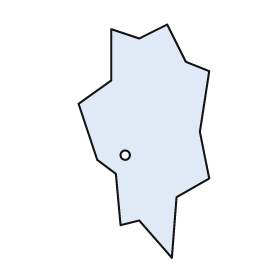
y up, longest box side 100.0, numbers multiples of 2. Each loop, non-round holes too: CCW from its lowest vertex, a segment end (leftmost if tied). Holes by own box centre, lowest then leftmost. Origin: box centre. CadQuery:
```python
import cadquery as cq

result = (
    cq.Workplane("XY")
    .moveTo(12.0, -50.0)
    .lineTo(14.0, -24.0)
    .lineTo(28.0, -16.0)
    .lineTo(24.0, 4.0)
    .lineTo(28.0, 30.0)
    .lineTo(18.0, 34.0)
    .lineTo(10.0, 50.0)
    .lineTo(-2.0, 44.0)
    .lineTo(-14.0, 48.0)
    .lineTo(-14.0, 26.0)
    .lineTo(-28.0, 16.0)
    .lineTo(-20.0, -8.0)
    .lineTo(-12.0, -14.0)
    .lineTo(-10.0, -36.0)
    .lineTo(-2.0, -34.0)
    .close()
    .moveTo(-8.0, -6.0)
    .circle(2.0)
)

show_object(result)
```